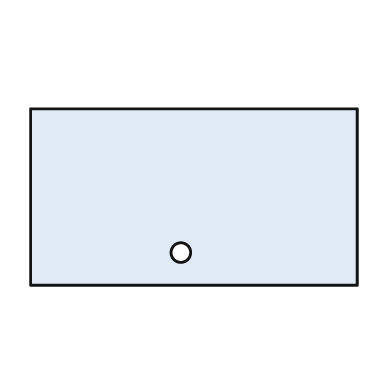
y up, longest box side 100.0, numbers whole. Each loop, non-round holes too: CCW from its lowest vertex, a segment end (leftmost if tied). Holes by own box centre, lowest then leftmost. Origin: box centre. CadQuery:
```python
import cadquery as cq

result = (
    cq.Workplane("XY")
    .moveTo(-50.0, -27.0)
    .lineTo(50.0, -27.0)
    .lineTo(50.0, 27.0)
    .lineTo(-50.0, 27.0)
    .close()
    .moveTo(-4.0, -17.0)
    .circle(3.0)
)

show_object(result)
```